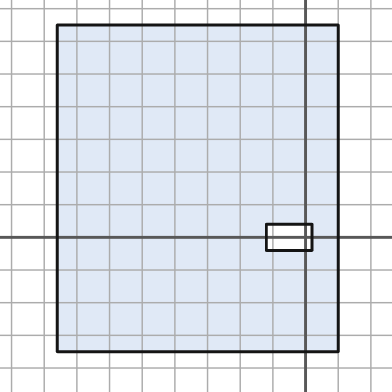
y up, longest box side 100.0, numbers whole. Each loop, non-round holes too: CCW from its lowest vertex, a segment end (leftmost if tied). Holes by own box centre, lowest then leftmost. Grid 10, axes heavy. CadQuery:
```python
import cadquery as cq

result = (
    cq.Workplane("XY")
    .moveTo(-76.0, -35.0)
    .lineTo(10.0, -35.0)
    .lineTo(10.0, 65.0)
    .lineTo(-76.0, 65.0)
    .close()
    .moveTo(-12.0, -4.0)
    .lineTo(2.0, -4.0)
    .lineTo(2.0, 4.0)
    .lineTo(-12.0, 4.0)
    .close()
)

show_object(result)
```